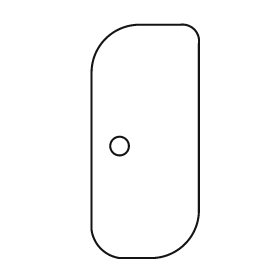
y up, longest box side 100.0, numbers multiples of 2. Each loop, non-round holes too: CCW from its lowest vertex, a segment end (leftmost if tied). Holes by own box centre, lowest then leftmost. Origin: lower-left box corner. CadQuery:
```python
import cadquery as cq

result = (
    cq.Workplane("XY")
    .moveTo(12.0, 0.0)
    .lineTo(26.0, 0.0)
    .threePointArc((40.0, 6.0), (46.0, 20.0))
    .lineTo(46.0, 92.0)
    .threePointArc((44.0, 98.0), (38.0, 100.0))
    .lineTo(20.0, 100.0)
    .threePointArc((6.0, 94.0), (0.0, 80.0))
    .lineTo(0.0, 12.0)
    .threePointArc((4.0, 4.0), (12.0, 0.0))
    .close()
    .moveTo(12.0, 48.0)
    .circle(4.0)
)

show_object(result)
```